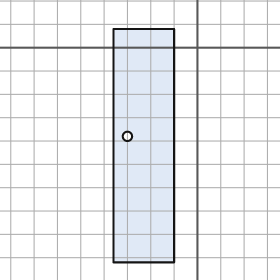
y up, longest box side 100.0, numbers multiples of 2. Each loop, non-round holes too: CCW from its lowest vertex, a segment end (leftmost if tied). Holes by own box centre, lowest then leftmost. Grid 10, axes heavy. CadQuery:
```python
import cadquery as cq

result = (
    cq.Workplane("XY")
    .moveTo(-36.0, -92.0)
    .lineTo(-10.0, -92.0)
    .lineTo(-10.0, 8.0)
    .lineTo(-36.0, 8.0)
    .close()
    .moveTo(-30.0, -38.0)
    .circle(2.0)
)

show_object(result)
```